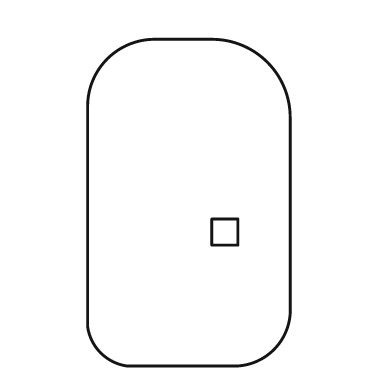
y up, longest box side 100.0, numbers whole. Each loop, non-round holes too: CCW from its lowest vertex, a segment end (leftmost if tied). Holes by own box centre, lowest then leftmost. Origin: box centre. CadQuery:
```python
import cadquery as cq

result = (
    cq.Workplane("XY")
    .moveTo(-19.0, -50.0)
    .lineTo(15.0, -50.0)
    .threePointArc((26.0, -45.0), (31.0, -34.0))
    .lineTo(31.0, 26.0)
    .threePointArc((24.0, 43.0), (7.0, 50.0))
    .lineTo(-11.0, 50.0)
    .threePointArc((-25.0, 44.0), (-31.0, 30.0))
    .lineTo(-31.0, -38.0)
    .threePointArc((-27.0, -46.0), (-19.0, -50.0))
    .close()
    .moveTo(7.0, -13.0)
    .lineTo(15.0, -13.0)
    .lineTo(15.0, -5.0)
    .lineTo(7.0, -5.0)
    .close()
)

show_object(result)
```